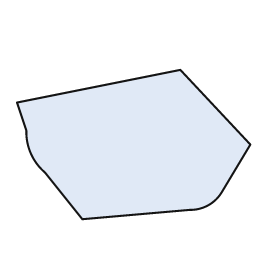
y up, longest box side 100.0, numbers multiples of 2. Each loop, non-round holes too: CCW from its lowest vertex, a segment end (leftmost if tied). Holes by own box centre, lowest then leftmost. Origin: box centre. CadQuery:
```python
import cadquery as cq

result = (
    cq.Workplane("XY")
    .moveTo(-22.0, -32.0)
    .lineTo(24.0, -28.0)
    .threePointArc((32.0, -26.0), (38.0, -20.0))
    .lineTo(50.0, 0.0)
    .lineTo(20.0, 32.0)
    .lineTo(-50.0, 18.0)
    .lineTo(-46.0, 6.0)
    .threePointArc((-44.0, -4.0), (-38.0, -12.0))
    .close()
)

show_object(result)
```